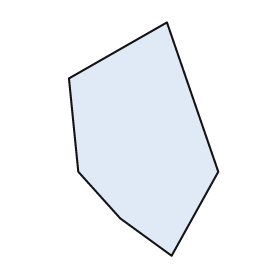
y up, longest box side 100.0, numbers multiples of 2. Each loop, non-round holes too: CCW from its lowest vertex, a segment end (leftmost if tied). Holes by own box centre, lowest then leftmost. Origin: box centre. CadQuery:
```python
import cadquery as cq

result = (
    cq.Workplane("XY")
    .moveTo(12.0, -50.0)
    .lineTo(32.0, -14.0)
    .lineTo(10.0, 50.0)
    .lineTo(-32.0, 26.0)
    .lineTo(-28.0, -14.0)
    .lineTo(-10.0, -34.0)
    .close()
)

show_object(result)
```